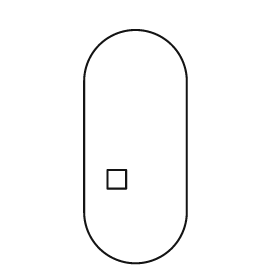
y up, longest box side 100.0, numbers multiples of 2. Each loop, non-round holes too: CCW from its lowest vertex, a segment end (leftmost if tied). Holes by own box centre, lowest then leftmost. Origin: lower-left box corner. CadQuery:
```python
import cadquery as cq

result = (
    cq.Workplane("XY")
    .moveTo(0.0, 22.0)
    .threePointArc((22.0, 0.0), (44.0, 22.0))
    .lineTo(44.0, 78.0)
    .threePointArc((22.0, 100.0), (0.0, 78.0))
    .close()
    .moveTo(10.0, 32.0)
    .lineTo(18.0, 32.0)
    .lineTo(18.0, 40.0)
    .lineTo(10.0, 40.0)
    .close()
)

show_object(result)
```